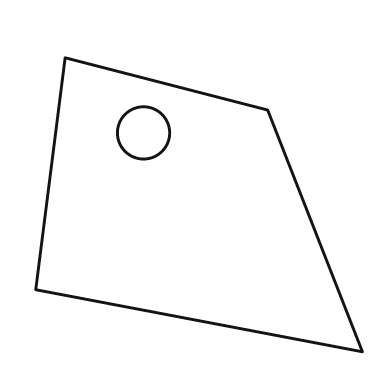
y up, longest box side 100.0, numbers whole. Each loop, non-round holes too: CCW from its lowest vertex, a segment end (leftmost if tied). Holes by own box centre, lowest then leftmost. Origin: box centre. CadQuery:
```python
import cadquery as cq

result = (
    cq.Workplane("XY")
    .moveTo(50.0, -45.0)
    .lineTo(21.0, 29.0)
    .lineTo(-41.0, 45.0)
    .lineTo(-50.0, -26.0)
    .close()
    .moveTo(-17.0, 22.0)
    .circle(8.0)
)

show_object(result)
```